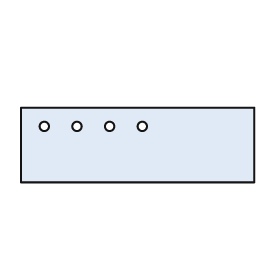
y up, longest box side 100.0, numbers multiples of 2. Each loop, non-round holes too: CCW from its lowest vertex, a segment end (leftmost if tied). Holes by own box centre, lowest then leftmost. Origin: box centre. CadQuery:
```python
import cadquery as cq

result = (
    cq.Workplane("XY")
    .moveTo(-50.0, -16.0)
    .lineTo(50.0, -16.0)
    .lineTo(50.0, 16.0)
    .lineTo(-50.0, 16.0)
    .close()
    .moveTo(-40.0, 8.0)
    .circle(2.0)
    .moveTo(-26.0, 8.0)
    .circle(2.0)
    .moveTo(-12.0, 8.0)
    .circle(2.0)
    .moveTo(2.0, 8.0)
    .circle(2.0)
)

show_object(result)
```